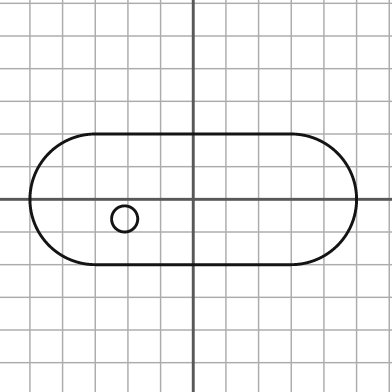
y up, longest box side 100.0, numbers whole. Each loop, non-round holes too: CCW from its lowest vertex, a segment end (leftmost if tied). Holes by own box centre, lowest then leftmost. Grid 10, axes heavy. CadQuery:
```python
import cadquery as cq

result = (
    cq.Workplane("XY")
    .moveTo(-30.0, -20.0)
    .lineTo(30.0, -20.0)
    .threePointArc((50.0, 0.0), (30.0, 20.0))
    .lineTo(-30.0, 20.0)
    .threePointArc((-50.0, 0.0), (-30.0, -20.0))
    .close()
    .moveTo(-21.0, -6.0)
    .circle(4.0)
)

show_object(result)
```